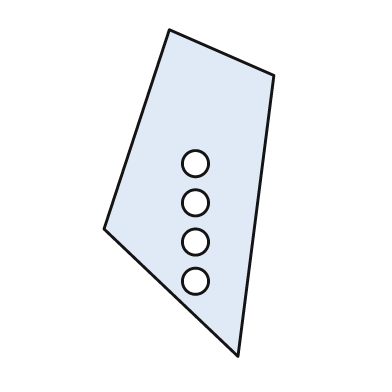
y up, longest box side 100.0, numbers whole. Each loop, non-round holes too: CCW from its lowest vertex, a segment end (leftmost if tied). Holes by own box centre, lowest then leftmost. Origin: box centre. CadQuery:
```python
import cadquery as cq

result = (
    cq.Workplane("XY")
    .moveTo(15.0, -50.0)
    .lineTo(26.0, 36.0)
    .lineTo(-6.0, 50.0)
    .lineTo(-26.0, -11.0)
    .close()
    .moveTo(2.0, -27.0)
    .circle(4.0)
    .moveTo(2.0, -15.0)
    .circle(4.0)
    .moveTo(2.0, -3.0)
    .circle(4.0)
    .moveTo(2.0, 9.0)
    .circle(4.0)
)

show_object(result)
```